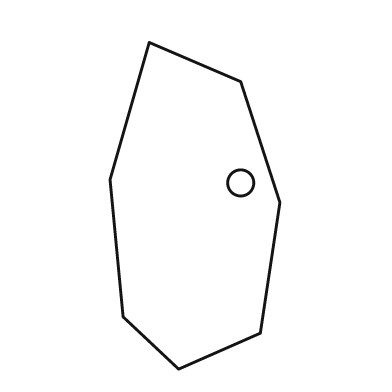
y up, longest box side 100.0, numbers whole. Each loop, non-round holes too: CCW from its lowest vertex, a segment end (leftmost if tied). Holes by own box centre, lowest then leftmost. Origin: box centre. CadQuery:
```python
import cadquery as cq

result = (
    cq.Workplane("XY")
    .moveTo(-5.0, -50.0)
    .lineTo(20.0, -39.0)
    .lineTo(26.0, 1.0)
    .lineTo(14.0, 38.0)
    .lineTo(-14.0, 50.0)
    .lineTo(-26.0, 8.0)
    .lineTo(-22.0, -34.0)
    .close()
    .moveTo(14.0, 7.0)
    .circle(4.0)
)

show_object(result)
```